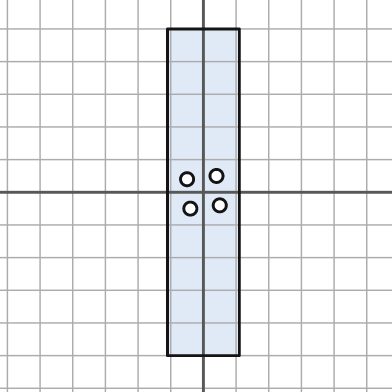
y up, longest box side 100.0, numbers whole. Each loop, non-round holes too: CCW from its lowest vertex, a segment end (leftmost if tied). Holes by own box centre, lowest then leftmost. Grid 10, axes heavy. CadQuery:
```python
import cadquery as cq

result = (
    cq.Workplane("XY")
    .moveTo(-11.0, -50.0)
    .lineTo(11.0, -50.0)
    .lineTo(11.0, 50.0)
    .lineTo(-11.0, 50.0)
    .close()
    .moveTo(-4.0, -5.0)
    .circle(2.0)
    .moveTo(5.0, -4.0)
    .circle(2.0)
    .moveTo(-5.0, 4.0)
    .circle(2.0)
    .moveTo(4.0, 5.0)
    .circle(2.0)
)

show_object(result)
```